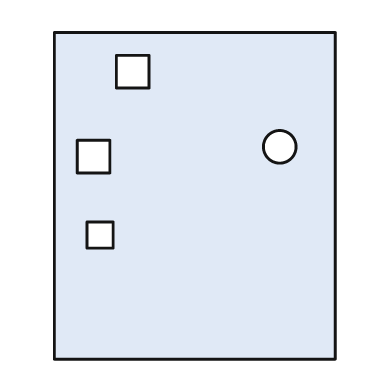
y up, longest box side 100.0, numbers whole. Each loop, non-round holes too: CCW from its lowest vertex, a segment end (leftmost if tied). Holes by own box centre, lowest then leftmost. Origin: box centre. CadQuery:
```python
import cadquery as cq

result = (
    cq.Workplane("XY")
    .moveTo(-43.0, -50.0)
    .lineTo(43.0, -50.0)
    .lineTo(43.0, 50.0)
    .lineTo(-43.0, 50.0)
    .close()
    .moveTo(-33.0, -16.0)
    .lineTo(-25.0, -16.0)
    .lineTo(-25.0, -8.0)
    .lineTo(-33.0, -8.0)
    .close()
    .moveTo(-36.0, 7.0)
    .lineTo(-26.0, 7.0)
    .lineTo(-26.0, 17.0)
    .lineTo(-36.0, 17.0)
    .close()
    .moveTo(26.0, 15.0)
    .circle(5.0)
    .moveTo(-24.0, 33.0)
    .lineTo(-14.0, 33.0)
    .lineTo(-14.0, 43.0)
    .lineTo(-24.0, 43.0)
    .close()
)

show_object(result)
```